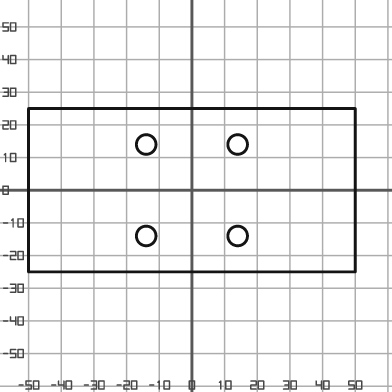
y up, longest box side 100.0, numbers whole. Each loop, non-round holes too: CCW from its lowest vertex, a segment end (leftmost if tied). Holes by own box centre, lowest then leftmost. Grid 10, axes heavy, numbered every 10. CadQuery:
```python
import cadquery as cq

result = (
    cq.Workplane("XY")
    .moveTo(-50.0, -25.0)
    .lineTo(50.0, -25.0)
    .lineTo(50.0, 25.0)
    .lineTo(-50.0, 25.0)
    .close()
    .moveTo(-14.0, -14.0)
    .circle(3.0)
    .moveTo(14.0, -14.0)
    .circle(3.0)
    .moveTo(-14.0, 14.0)
    .circle(3.0)
    .moveTo(14.0, 14.0)
    .circle(3.0)
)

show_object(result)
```